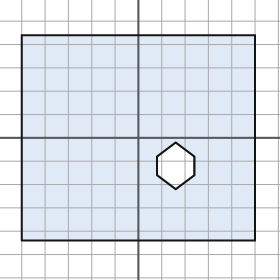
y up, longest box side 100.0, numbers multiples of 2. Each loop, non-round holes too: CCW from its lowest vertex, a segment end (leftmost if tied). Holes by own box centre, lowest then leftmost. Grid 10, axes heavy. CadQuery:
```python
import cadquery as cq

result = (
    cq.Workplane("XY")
    .moveTo(-50.0, -44.0)
    .lineTo(50.0, -44.0)
    .lineTo(50.0, 44.0)
    .lineTo(-50.0, 44.0)
    .close()
    .moveTo(16.0, -22.0)
    .lineTo(24.0, -16.0)
    .lineTo(24.0, -8.0)
    .lineTo(16.0, -2.0)
    .lineTo(8.0, -8.0)
    .lineTo(8.0, -16.0)
    .close()
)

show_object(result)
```